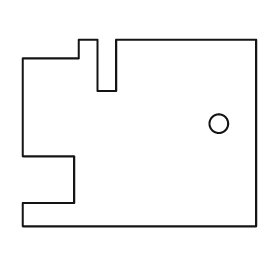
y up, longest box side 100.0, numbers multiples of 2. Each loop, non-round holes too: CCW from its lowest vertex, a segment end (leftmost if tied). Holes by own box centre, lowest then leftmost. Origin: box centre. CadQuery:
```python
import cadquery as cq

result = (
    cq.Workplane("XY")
    .moveTo(-50.0, -40.0)
    .lineTo(50.0, -40.0)
    .lineTo(50.0, 40.0)
    .lineTo(-10.0, 40.0)
    .lineTo(-10.0, 18.0)
    .lineTo(-18.0, 18.0)
    .lineTo(-18.0, 40.0)
    .lineTo(-26.0, 40.0)
    .lineTo(-26.0, 32.0)
    .lineTo(-50.0, 32.0)
    .lineTo(-50.0, -10.0)
    .lineTo(-28.0, -10.0)
    .lineTo(-28.0, -30.0)
    .lineTo(-50.0, -30.0)
    .close()
    .moveTo(34.0, 4.0)
    .circle(4.0)
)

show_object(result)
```